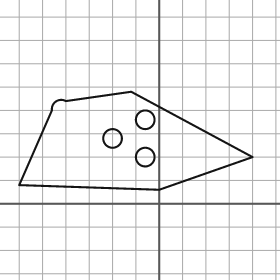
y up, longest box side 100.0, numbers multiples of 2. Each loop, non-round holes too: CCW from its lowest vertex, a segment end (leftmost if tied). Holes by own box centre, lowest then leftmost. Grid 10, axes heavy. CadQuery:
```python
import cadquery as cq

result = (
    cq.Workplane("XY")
    .moveTo(0.0, 6.0)
    .lineTo(40.0, 20.0)
    .lineTo(-12.0, 48.0)
    .lineTo(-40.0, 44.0)
    .threePointArc((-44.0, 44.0), (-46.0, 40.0))
    .lineTo(-60.0, 8.0)
    .close()
    .moveTo(-6.0, 20.0)
    .circle(4.0)
    .moveTo(-20.0, 28.0)
    .circle(4.0)
    .moveTo(-6.0, 36.0)
    .circle(4.0)
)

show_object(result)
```